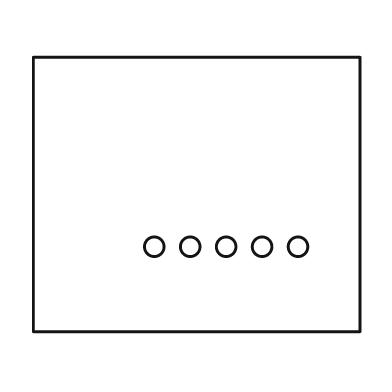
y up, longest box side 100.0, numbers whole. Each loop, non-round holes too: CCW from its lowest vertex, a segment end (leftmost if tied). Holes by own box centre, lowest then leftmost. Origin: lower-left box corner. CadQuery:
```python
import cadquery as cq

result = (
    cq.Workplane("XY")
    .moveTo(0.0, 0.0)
    .lineTo(100.0, 0.0)
    .lineTo(100.0, 84.0)
    .lineTo(0.0, 84.0)
    .close()
    .moveTo(37.0, 26.0)
    .circle(3.0)
    .moveTo(48.0, 26.0)
    .circle(3.0)
    .moveTo(59.0, 26.0)
    .circle(3.0)
    .moveTo(70.0, 26.0)
    .circle(3.0)
    .moveTo(81.0, 26.0)
    .circle(3.0)
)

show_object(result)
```